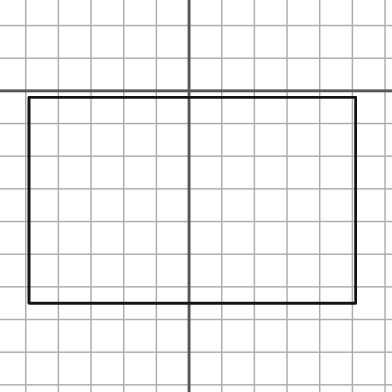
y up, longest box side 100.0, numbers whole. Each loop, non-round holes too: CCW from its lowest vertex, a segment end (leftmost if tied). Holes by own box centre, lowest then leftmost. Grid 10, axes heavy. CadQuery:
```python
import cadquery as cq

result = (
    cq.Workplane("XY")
    .moveTo(-49.0, -65.0)
    .lineTo(51.0, -65.0)
    .lineTo(51.0, -2.0)
    .lineTo(-49.0, -2.0)
    .close()
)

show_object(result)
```